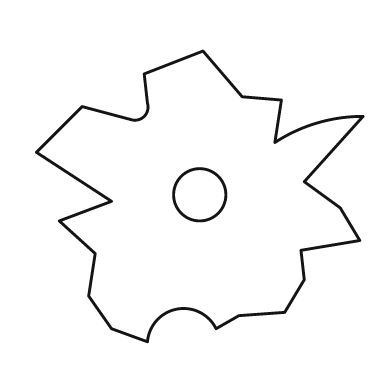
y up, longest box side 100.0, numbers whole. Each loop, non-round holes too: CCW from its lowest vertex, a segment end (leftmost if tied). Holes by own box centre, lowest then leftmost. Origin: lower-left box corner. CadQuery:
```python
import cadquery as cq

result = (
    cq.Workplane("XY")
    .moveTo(34.0, 0.0)
    .threePointArc((43.0, 10.0), (55.0, 4.0))
    .lineTo(62.0, 8.0)
    .lineTo(76.0, 9.0)
    .lineTo(82.0, 19.0)
    .lineTo(81.0, 28.0)
    .lineTo(99.0, 31.0)
    .lineTo(93.0, 41.0)
    .lineTo(82.0, 49.0)
    .lineTo(100.0, 69.0)
    .threePointArc((86.0, 67.0), (73.0, 61.0))
    .lineTo(75.0, 74.0)
    .lineTo(63.0, 75.0)
    .lineTo(51.0, 89.0)
    .lineTo(33.0, 82.0)
    .lineTo(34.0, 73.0)
    .threePointArc((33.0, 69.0), (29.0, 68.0))
    .lineTo(14.0, 72.0)
    .lineTo(0.0, 58.0)
    .lineTo(23.0, 43.0)
    .lineTo(7.0, 37.0)
    .lineTo(18.0, 27.0)
    .lineTo(16.0, 14.0)
    .lineTo(23.0, 4.0)
    .close()
    .moveTo(50.0, 45.0)
    .circle(8.0)
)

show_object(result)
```